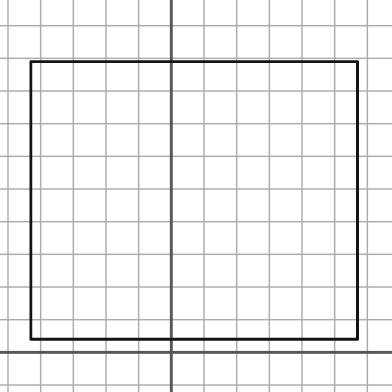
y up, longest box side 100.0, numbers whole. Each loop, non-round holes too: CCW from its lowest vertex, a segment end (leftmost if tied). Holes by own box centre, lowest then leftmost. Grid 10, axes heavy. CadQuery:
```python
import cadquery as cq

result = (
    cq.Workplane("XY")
    .moveTo(-43.0, 4.0)
    .lineTo(57.0, 4.0)
    .lineTo(57.0, 89.0)
    .lineTo(-43.0, 89.0)
    .close()
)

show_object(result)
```